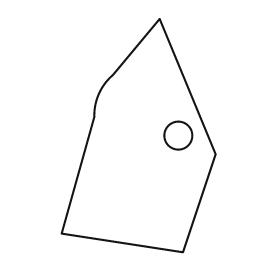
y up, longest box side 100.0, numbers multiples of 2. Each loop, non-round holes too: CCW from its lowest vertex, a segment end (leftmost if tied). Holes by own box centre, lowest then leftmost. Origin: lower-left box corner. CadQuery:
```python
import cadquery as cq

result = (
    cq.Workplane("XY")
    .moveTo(52.0, 0.0)
    .lineTo(66.0, 42.0)
    .lineTo(42.0, 100.0)
    .lineTo(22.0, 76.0)
    .threePointArc((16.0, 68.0), (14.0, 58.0))
    .lineTo(0.0, 8.0)
    .close()
    .moveTo(50.0, 50.0)
    .circle(6.0)
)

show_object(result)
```